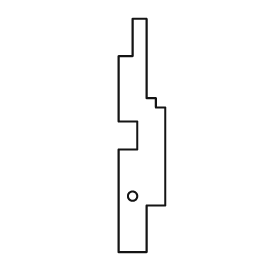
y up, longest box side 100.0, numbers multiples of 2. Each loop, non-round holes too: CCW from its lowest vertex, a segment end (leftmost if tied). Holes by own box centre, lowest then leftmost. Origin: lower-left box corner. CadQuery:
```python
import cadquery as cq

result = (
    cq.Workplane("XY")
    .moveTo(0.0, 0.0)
    .lineTo(12.0, 0.0)
    .lineTo(12.0, 20.0)
    .lineTo(20.0, 20.0)
    .lineTo(20.0, 62.0)
    .lineTo(16.0, 62.0)
    .lineTo(16.0, 66.0)
    .lineTo(12.0, 66.0)
    .lineTo(12.0, 100.0)
    .lineTo(6.0, 100.0)
    .lineTo(6.0, 84.0)
    .lineTo(0.0, 84.0)
    .lineTo(0.0, 56.0)
    .lineTo(8.0, 56.0)
    .lineTo(8.0, 44.0)
    .lineTo(0.0, 44.0)
    .close()
    .moveTo(6.0, 24.0)
    .circle(2.0)
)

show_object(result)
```